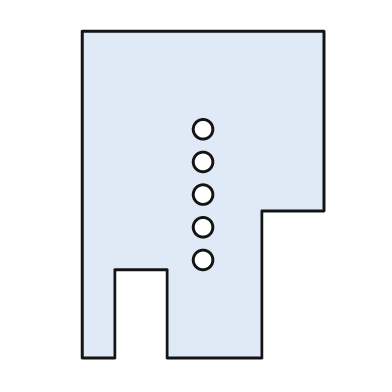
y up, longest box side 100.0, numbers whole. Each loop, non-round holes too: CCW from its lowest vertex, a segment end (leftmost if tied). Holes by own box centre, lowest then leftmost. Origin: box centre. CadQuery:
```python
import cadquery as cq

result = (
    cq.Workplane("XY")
    .moveTo(-37.0, -50.0)
    .lineTo(-27.0, -50.0)
    .lineTo(-27.0, -23.0)
    .lineTo(-11.0, -23.0)
    .lineTo(-11.0, -50.0)
    .lineTo(18.0, -50.0)
    .lineTo(18.0, -5.0)
    .lineTo(37.0, -5.0)
    .lineTo(37.0, 50.0)
    .lineTo(-37.0, 50.0)
    .close()
    .moveTo(0.0, -20.0)
    .circle(3.0)
    .moveTo(0.0, -10.0)
    .circle(3.0)
    .moveTo(0.0, 0.0)
    .circle(3.0)
    .moveTo(0.0, 10.0)
    .circle(3.0)
    .moveTo(0.0, 20.0)
    .circle(3.0)
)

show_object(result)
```